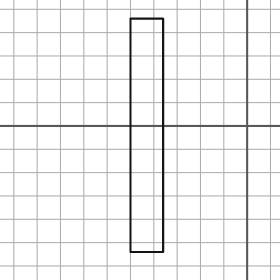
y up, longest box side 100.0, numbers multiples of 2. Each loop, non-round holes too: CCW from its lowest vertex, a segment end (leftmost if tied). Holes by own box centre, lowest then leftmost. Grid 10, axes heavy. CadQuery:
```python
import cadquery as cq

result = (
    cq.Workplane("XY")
    .moveTo(-50.0, -54.0)
    .lineTo(-36.0, -54.0)
    .lineTo(-36.0, 46.0)
    .lineTo(-50.0, 46.0)
    .close()
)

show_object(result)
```